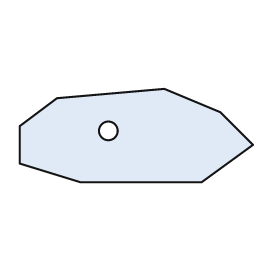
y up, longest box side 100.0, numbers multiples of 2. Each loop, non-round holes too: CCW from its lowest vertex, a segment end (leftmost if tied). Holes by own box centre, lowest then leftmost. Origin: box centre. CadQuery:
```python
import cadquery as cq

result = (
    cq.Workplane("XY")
    .moveTo(-24.0, -20.0)
    .lineTo(28.0, -20.0)
    .lineTo(50.0, -4.0)
    .lineTo(36.0, 10.0)
    .lineTo(12.0, 20.0)
    .lineTo(-34.0, 16.0)
    .lineTo(-50.0, 4.0)
    .lineTo(-50.0, -12.0)
    .close()
    .moveTo(-12.0, 2.0)
    .circle(4.0)
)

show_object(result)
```